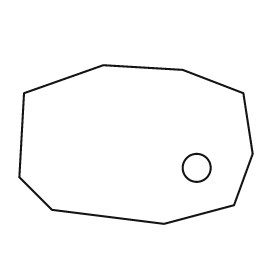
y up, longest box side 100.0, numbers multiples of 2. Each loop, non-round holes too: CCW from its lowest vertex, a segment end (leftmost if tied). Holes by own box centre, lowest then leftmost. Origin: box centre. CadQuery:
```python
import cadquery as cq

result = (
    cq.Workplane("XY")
    .moveTo(12.0, -34.0)
    .lineTo(42.0, -26.0)
    .lineTo(50.0, -4.0)
    .lineTo(46.0, 22.0)
    .lineTo(20.0, 32.0)
    .lineTo(-14.0, 34.0)
    .lineTo(-48.0, 22.0)
    .lineTo(-50.0, -14.0)
    .lineTo(-36.0, -28.0)
    .close()
    .moveTo(26.0, -10.0)
    .circle(6.0)
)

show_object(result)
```